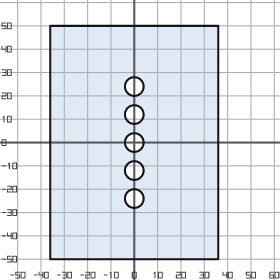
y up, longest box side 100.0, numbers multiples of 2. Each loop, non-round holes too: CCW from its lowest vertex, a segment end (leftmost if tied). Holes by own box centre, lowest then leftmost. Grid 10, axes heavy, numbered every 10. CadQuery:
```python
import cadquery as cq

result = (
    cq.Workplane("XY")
    .moveTo(-36.0, -50.0)
    .lineTo(36.0, -50.0)
    .lineTo(36.0, 50.0)
    .lineTo(-36.0, 50.0)
    .close()
    .moveTo(0.0, -24.0)
    .circle(4.0)
    .moveTo(0.0, -12.0)
    .circle(4.0)
    .moveTo(0.0, 0.0)
    .circle(4.0)
    .moveTo(0.0, 12.0)
    .circle(4.0)
    .moveTo(0.0, 24.0)
    .circle(4.0)
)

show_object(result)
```